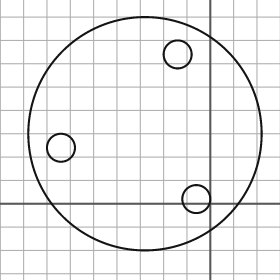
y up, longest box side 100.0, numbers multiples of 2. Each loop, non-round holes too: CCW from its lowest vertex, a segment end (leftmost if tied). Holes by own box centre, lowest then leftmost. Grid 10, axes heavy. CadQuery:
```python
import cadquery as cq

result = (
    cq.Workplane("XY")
    .moveTo(-28.0, 30.0)
    .circle(50.0)
    .moveTo(-6.0, 2.0)
    .circle(6.0)
    .moveTo(-64.0, 24.0)
    .circle(6.0)
    .moveTo(-14.0, 64.0)
    .circle(6.0)
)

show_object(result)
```